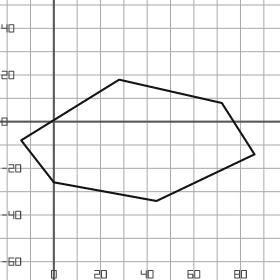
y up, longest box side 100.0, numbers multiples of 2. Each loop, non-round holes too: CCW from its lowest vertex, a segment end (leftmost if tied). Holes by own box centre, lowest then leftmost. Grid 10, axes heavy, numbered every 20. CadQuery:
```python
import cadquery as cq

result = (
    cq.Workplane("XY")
    .moveTo(44.0, -34.0)
    .lineTo(86.0, -14.0)
    .lineTo(72.0, 8.0)
    .lineTo(28.0, 18.0)
    .lineTo(-14.0, -8.0)
    .lineTo(0.0, -26.0)
    .close()
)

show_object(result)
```